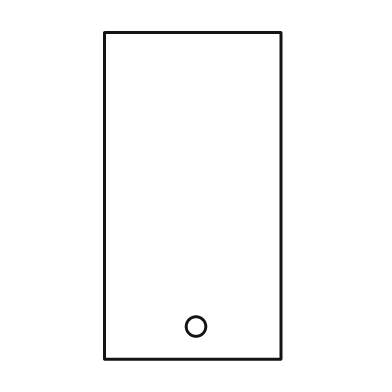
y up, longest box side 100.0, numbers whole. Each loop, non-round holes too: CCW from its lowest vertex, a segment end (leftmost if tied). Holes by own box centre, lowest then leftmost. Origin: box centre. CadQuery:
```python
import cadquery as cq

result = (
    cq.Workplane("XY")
    .moveTo(-27.0, -50.0)
    .lineTo(27.0, -50.0)
    .lineTo(27.0, 50.0)
    .lineTo(-27.0, 50.0)
    .close()
    .moveTo(1.0, -40.0)
    .circle(3.0)
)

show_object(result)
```